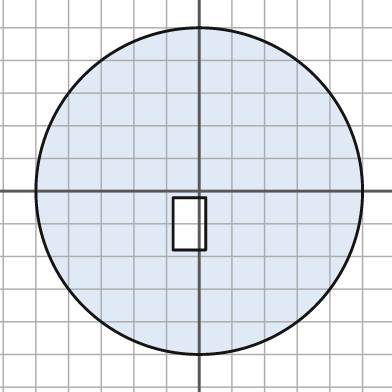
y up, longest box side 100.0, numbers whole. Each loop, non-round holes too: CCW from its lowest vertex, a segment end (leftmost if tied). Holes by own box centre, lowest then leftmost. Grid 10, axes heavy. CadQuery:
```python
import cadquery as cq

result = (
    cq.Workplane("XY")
    .moveTo(0.0, 0.0)
    .circle(50.0)
    .moveTo(-8.0, -18.0)
    .lineTo(2.0, -18.0)
    .lineTo(2.0, -2.0)
    .lineTo(-8.0, -2.0)
    .close()
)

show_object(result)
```